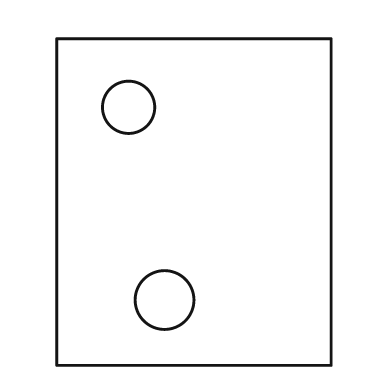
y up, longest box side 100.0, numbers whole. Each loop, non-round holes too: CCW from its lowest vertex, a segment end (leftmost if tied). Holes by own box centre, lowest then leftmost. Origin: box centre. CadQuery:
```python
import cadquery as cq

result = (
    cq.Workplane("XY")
    .moveTo(-42.0, -50.0)
    .lineTo(42.0, -50.0)
    .lineTo(42.0, 50.0)
    .lineTo(-42.0, 50.0)
    .close()
    .moveTo(-9.0, -30.0)
    .circle(9.0)
    .moveTo(-20.0, 29.0)
    .circle(8.0)
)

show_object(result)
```